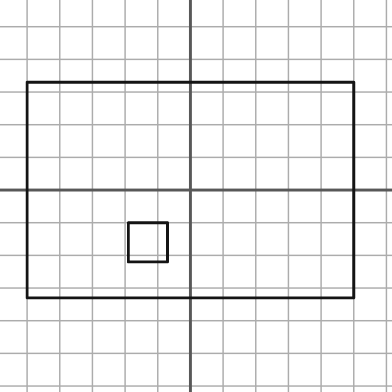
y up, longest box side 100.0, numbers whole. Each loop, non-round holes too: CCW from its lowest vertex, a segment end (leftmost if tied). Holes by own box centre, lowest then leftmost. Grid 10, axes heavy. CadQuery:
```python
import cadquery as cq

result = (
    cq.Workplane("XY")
    .moveTo(-50.0, -33.0)
    .lineTo(50.0, -33.0)
    .lineTo(50.0, 33.0)
    .lineTo(-50.0, 33.0)
    .close()
    .moveTo(-19.0, -22.0)
    .lineTo(-7.0, -22.0)
    .lineTo(-7.0, -10.0)
    .lineTo(-19.0, -10.0)
    .close()
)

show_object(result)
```